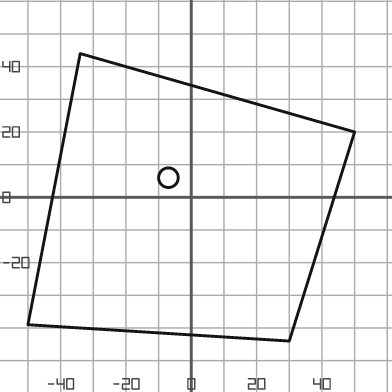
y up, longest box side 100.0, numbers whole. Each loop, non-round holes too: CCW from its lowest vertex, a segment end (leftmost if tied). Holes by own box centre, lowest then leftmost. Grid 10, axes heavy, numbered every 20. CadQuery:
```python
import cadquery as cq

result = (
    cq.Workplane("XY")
    .moveTo(30.0, -44.0)
    .lineTo(50.0, 20.0)
    .lineTo(-34.0, 44.0)
    .lineTo(-50.0, -39.0)
    .close()
    .moveTo(-7.0, 6.0)
    .circle(3.0)
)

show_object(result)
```